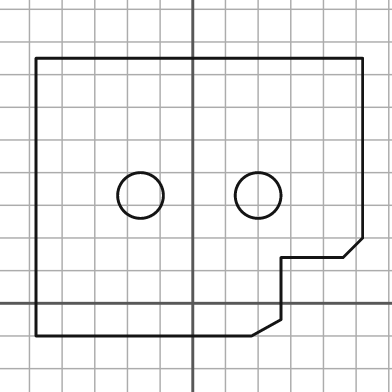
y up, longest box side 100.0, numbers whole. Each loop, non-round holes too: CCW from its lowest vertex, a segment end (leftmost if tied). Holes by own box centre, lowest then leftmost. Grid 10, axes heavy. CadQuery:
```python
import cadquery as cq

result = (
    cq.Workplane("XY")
    .moveTo(-48.0, -10.0)
    .lineTo(18.0, -10.0)
    .lineTo(27.0, -5.0)
    .lineTo(27.0, 14.0)
    .lineTo(46.0, 14.0)
    .lineTo(52.0, 20.0)
    .lineTo(52.0, 75.0)
    .lineTo(-48.0, 75.0)
    .close()
    .moveTo(-16.0, 33.0)
    .circle(7.0)
    .moveTo(20.0, 33.0)
    .circle(7.0)
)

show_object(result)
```